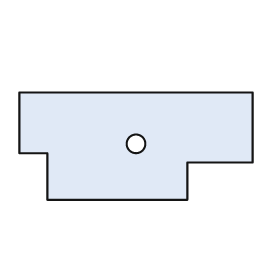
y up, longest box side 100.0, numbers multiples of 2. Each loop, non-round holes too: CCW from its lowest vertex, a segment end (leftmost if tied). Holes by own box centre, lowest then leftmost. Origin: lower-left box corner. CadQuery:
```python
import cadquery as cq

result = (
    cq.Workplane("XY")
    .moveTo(12.0, 0.0)
    .lineTo(72.0, 0.0)
    .lineTo(72.0, 16.0)
    .lineTo(100.0, 16.0)
    .lineTo(100.0, 46.0)
    .lineTo(0.0, 46.0)
    .lineTo(0.0, 20.0)
    .lineTo(12.0, 20.0)
    .close()
    .moveTo(50.0, 24.0)
    .circle(4.0)
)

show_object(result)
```